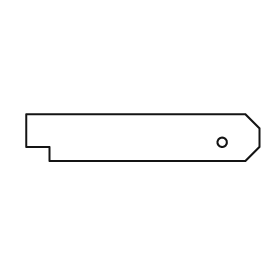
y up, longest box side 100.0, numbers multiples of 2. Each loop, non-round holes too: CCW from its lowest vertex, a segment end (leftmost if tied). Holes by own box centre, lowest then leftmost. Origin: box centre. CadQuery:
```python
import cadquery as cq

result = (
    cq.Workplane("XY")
    .moveTo(-40.0, -10.0)
    .lineTo(44.0, -10.0)
    .lineTo(50.0, -4.0)
    .lineTo(50.0, 4.0)
    .lineTo(44.0, 10.0)
    .lineTo(-50.0, 10.0)
    .lineTo(-50.0, -4.0)
    .lineTo(-40.0, -4.0)
    .close()
    .moveTo(34.0, -2.0)
    .circle(2.0)
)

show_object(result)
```